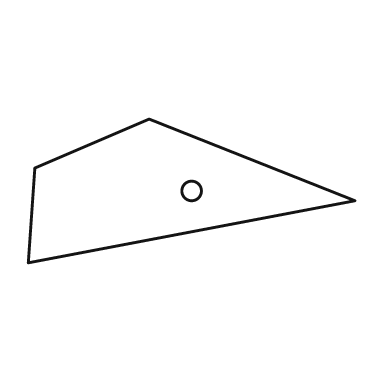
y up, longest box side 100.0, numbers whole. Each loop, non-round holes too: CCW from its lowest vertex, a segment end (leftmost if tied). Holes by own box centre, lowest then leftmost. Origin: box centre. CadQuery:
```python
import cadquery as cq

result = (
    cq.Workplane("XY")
    .moveTo(-50.0, -22.0)
    .lineTo(50.0, -3.0)
    .lineTo(-13.0, 22.0)
    .lineTo(-48.0, 7.0)
    .close()
    .moveTo(0.0, 0.0)
    .circle(3.0)
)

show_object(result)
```